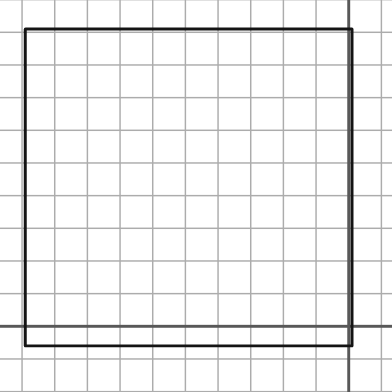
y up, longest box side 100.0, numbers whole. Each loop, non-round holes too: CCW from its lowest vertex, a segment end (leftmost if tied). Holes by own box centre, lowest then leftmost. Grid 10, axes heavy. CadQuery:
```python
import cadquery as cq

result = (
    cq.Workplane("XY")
    .moveTo(-99.0, -6.0)
    .lineTo(1.0, -6.0)
    .lineTo(1.0, 91.0)
    .lineTo(-99.0, 91.0)
    .close()
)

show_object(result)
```